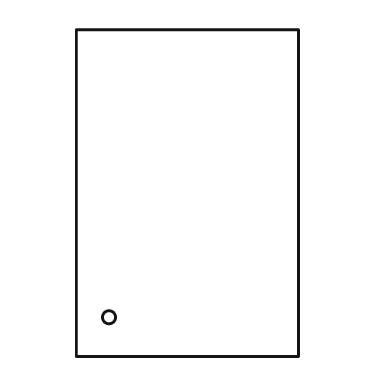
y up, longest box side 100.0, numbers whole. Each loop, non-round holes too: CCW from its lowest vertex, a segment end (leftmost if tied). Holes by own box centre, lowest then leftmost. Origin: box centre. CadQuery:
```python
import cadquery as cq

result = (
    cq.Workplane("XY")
    .moveTo(-34.0, -50.0)
    .lineTo(34.0, -50.0)
    .lineTo(34.0, 50.0)
    .lineTo(-34.0, 50.0)
    .close()
    .moveTo(-24.0, -38.0)
    .circle(2.0)
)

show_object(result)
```